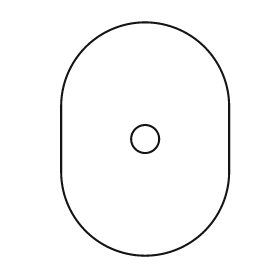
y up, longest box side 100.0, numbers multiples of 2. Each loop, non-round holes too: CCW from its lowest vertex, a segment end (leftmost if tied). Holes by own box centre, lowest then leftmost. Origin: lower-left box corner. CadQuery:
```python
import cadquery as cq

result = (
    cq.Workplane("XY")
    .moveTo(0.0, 36.0)
    .threePointArc((36.0, 0.0), (72.0, 36.0))
    .lineTo(72.0, 64.0)
    .threePointArc((36.0, 100.0), (0.0, 64.0))
    .close()
    .moveTo(36.0, 50.0)
    .circle(6.0)
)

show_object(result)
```